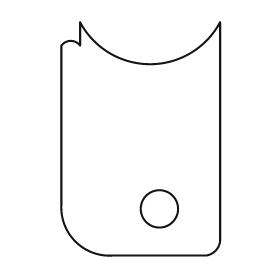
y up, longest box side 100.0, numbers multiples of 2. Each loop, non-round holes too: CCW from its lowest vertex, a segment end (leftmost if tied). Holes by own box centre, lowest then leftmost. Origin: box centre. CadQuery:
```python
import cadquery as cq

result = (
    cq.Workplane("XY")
    .moveTo(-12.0, -50.0)
    .lineTo(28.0, -50.0)
    .threePointArc((32.0, -48.0), (34.0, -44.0))
    .lineTo(34.0, 50.0)
    .threePointArc((4.0, 32.0), (-26.0, 50.0))
    .lineTo(-26.0, 40.0)
    .threePointArc((-30.0, 42.0), (-34.0, 40.0))
    .lineTo(-34.0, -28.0)
    .threePointArc((-28.0, -44.0), (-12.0, -50.0))
    .close()
    .moveTo(8.0, -30.0)
    .circle(8.0)
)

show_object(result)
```